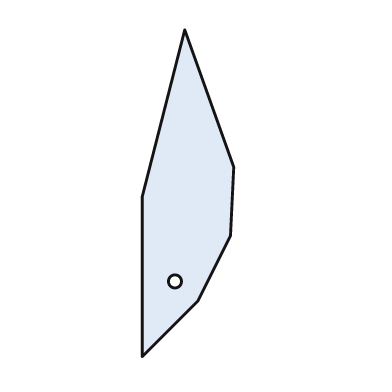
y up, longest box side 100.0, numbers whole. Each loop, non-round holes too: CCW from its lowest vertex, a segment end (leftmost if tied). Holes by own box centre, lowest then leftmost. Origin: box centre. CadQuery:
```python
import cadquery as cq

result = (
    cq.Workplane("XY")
    .moveTo(-14.0, -50.0)
    .lineTo(3.0, -33.0)
    .lineTo(13.0, -13.0)
    .lineTo(14.0, 8.0)
    .lineTo(-1.0, 50.0)
    .lineTo(-14.0, -1.0)
    .close()
    .moveTo(-4.0, -27.0)
    .circle(2.0)
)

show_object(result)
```